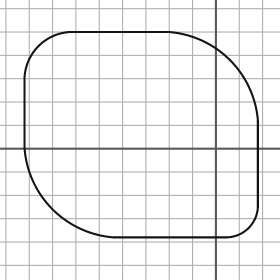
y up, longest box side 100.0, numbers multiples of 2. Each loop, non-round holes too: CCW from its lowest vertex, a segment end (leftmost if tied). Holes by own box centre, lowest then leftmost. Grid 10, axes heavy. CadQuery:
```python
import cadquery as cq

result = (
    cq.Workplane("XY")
    .moveTo(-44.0, -38.0)
    .lineTo(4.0, -38.0)
    .threePointArc((14.0, -34.0), (18.0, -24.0))
    .lineTo(18.0, 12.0)
    .threePointArc((6.0, 38.0), (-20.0, 50.0))
    .lineTo(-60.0, 50.0)
    .threePointArc((-76.0, 44.0), (-82.0, 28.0))
    .lineTo(-82.0, 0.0)
    .threePointArc((-70.0, -26.0), (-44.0, -38.0))
    .close()
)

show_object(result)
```